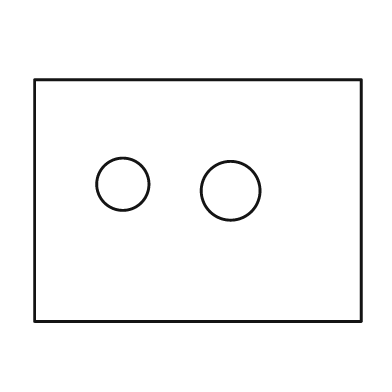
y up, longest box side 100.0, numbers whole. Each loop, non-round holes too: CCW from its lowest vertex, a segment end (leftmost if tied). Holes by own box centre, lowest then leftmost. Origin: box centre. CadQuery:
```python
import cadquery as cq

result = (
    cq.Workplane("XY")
    .moveTo(-50.0, -37.0)
    .lineTo(50.0, -37.0)
    .lineTo(50.0, 37.0)
    .lineTo(-50.0, 37.0)
    .close()
    .moveTo(10.0, 3.0)
    .circle(9.0)
    .moveTo(-23.0, 5.0)
    .circle(8.0)
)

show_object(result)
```